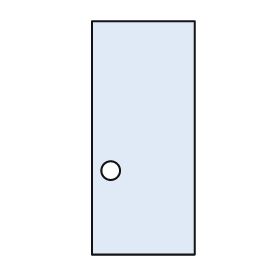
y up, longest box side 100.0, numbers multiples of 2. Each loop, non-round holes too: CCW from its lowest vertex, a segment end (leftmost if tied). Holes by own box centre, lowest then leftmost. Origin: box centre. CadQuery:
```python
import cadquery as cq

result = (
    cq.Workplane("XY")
    .moveTo(-22.0, -50.0)
    .lineTo(22.0, -50.0)
    .lineTo(22.0, 50.0)
    .lineTo(-22.0, 50.0)
    .close()
    .moveTo(-14.0, -14.0)
    .circle(4.0)
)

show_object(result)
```